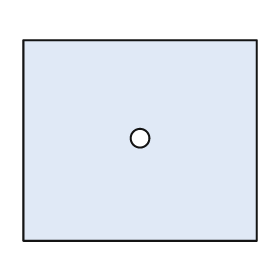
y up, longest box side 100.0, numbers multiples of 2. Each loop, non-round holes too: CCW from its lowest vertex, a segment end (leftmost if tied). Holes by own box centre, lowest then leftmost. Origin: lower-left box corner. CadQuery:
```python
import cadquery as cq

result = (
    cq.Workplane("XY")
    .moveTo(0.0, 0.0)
    .lineTo(100.0, 0.0)
    .lineTo(100.0, 86.0)
    .lineTo(0.0, 86.0)
    .close()
    .moveTo(50.0, 44.0)
    .circle(4.0)
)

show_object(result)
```